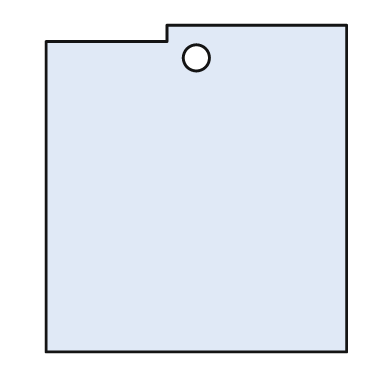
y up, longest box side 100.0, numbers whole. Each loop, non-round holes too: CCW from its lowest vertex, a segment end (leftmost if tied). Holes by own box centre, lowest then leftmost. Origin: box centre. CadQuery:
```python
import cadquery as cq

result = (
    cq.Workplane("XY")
    .moveTo(-46.0, -50.0)
    .lineTo(46.0, -50.0)
    .lineTo(46.0, 50.0)
    .lineTo(-9.0, 50.0)
    .lineTo(-9.0, 45.0)
    .lineTo(-46.0, 45.0)
    .close()
    .moveTo(0.0, 40.0)
    .circle(4.0)
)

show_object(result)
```